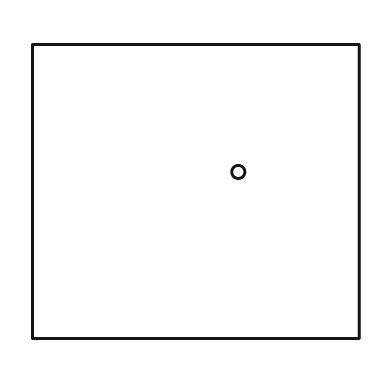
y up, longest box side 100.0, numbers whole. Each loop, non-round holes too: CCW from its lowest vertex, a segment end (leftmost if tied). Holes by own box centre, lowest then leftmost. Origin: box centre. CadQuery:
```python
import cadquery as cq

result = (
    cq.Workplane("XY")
    .moveTo(-50.0, -45.0)
    .lineTo(50.0, -45.0)
    .lineTo(50.0, 45.0)
    .lineTo(-50.0, 45.0)
    .close()
    .moveTo(13.0, 6.0)
    .circle(2.0)
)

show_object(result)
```